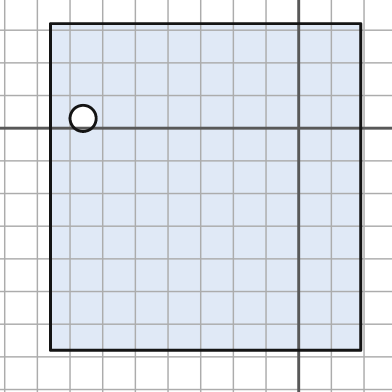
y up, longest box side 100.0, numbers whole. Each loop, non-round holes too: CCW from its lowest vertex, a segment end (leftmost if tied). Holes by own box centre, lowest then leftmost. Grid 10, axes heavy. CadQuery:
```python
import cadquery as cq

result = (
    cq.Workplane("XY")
    .moveTo(-76.0, -68.0)
    .lineTo(19.0, -68.0)
    .lineTo(19.0, 32.0)
    .lineTo(-76.0, 32.0)
    .close()
    .moveTo(-66.0, 3.0)
    .circle(4.0)
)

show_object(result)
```